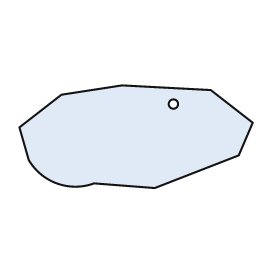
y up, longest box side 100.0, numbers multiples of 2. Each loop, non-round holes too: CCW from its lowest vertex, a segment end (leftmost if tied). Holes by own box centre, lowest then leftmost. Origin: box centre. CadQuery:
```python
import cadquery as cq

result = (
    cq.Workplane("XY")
    .moveTo(8.0, -22.0)
    .lineTo(44.0, -8.0)
    .lineTo(50.0, 6.0)
    .lineTo(32.0, 20.0)
    .lineTo(-6.0, 22.0)
    .lineTo(-32.0, 18.0)
    .lineTo(-50.0, 4.0)
    .lineTo(-46.0, -10.0)
    .threePointArc((-34.0, -20.0), (-18.0, -20.0))
    .close()
    .moveTo(16.0, 14.0)
    .circle(2.0)
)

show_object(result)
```